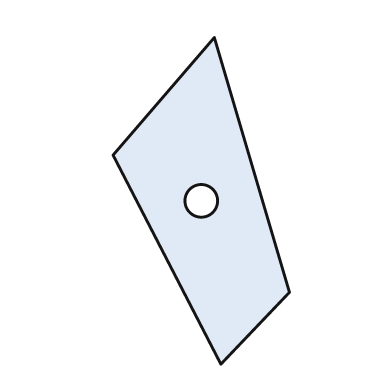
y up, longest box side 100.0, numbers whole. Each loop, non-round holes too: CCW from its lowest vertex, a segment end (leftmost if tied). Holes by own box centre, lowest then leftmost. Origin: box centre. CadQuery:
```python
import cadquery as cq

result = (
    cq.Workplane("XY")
    .moveTo(6.0, -50.0)
    .lineTo(27.0, -28.0)
    .lineTo(4.0, 50.0)
    .lineTo(-27.0, 14.0)
    .close()
    .moveTo(0.0, 0.0)
    .circle(5.0)
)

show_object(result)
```